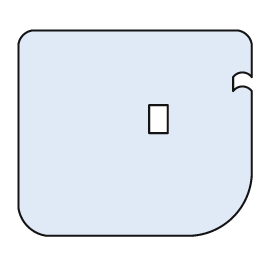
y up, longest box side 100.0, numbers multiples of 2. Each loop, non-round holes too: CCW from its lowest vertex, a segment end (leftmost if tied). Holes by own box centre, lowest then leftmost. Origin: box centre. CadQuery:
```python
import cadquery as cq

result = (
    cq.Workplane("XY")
    .moveTo(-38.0, -44.0)
    .lineTo(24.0, -44.0)
    .threePointArc((42.0, -36.0), (50.0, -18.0))
    .lineTo(50.0, 18.0)
    .threePointArc((46.0, 20.0), (42.0, 18.0))
    .lineTo(42.0, 24.0)
    .threePointArc((46.0, 26.0), (50.0, 24.0))
    .lineTo(50.0, 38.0)
    .threePointArc((48.0, 42.0), (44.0, 44.0))
    .lineTo(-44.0, 44.0)
    .threePointArc((-48.0, 42.0), (-50.0, 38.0))
    .lineTo(-50.0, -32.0)
    .threePointArc((-46.0, -40.0), (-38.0, -44.0))
    .close()
    .moveTo(6.0, 0.0)
    .lineTo(14.0, 0.0)
    .lineTo(14.0, 12.0)
    .lineTo(6.0, 12.0)
    .close()
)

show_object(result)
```